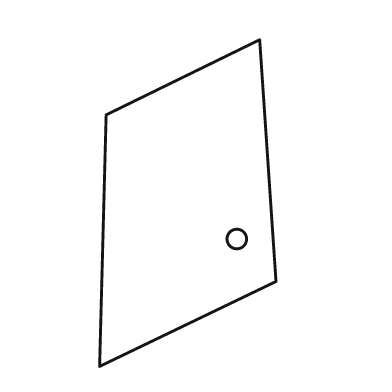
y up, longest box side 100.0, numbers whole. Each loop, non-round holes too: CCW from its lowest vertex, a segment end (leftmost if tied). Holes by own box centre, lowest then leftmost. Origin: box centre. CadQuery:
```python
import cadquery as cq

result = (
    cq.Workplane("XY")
    .moveTo(-27.0, -50.0)
    .lineTo(27.0, -24.0)
    .lineTo(22.0, 50.0)
    .lineTo(-25.0, 27.0)
    .close()
    .moveTo(15.0, -11.0)
    .circle(3.0)
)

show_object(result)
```